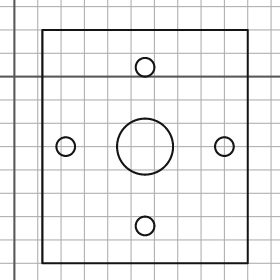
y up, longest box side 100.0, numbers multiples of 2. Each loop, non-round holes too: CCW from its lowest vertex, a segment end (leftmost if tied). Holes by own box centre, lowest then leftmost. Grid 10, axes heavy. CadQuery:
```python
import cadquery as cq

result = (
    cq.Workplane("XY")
    .moveTo(12.0, -80.0)
    .lineTo(100.0, -80.0)
    .lineTo(100.0, 20.0)
    .lineTo(12.0, 20.0)
    .close()
    .moveTo(56.0, -64.0)
    .circle(4.0)
    .moveTo(22.0, -30.0)
    .circle(4.0)
    .moveTo(56.0, -30.0)
    .circle(12.0)
    .moveTo(90.0, -30.0)
    .circle(4.0)
    .moveTo(56.0, 4.0)
    .circle(4.0)
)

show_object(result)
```